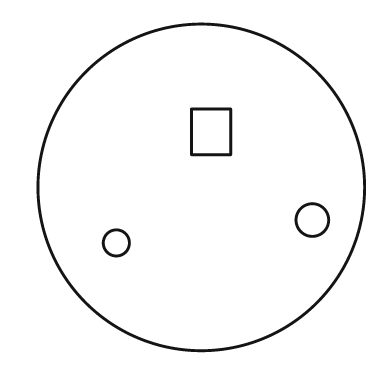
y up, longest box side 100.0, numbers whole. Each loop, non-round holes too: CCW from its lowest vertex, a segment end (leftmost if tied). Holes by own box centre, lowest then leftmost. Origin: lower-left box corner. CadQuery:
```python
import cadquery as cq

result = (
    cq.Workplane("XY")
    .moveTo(50.0, 50.0)
    .circle(50.0)
    .moveTo(24.0, 33.0)
    .circle(4.0)
    .moveTo(84.0, 40.0)
    .circle(5.0)
    .moveTo(47.0, 60.0)
    .lineTo(59.0, 60.0)
    .lineTo(59.0, 74.0)
    .lineTo(47.0, 74.0)
    .close()
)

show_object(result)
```